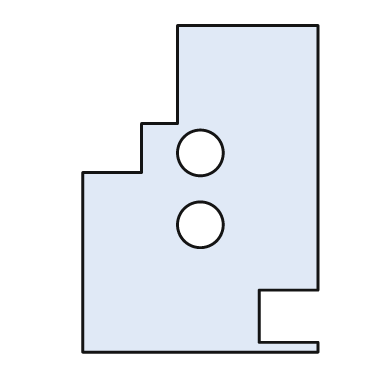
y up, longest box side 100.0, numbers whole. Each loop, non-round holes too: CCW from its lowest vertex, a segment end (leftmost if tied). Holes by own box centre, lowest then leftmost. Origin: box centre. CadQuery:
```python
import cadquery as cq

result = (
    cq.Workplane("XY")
    .moveTo(-36.0, -50.0)
    .lineTo(36.0, -50.0)
    .lineTo(36.0, -47.0)
    .lineTo(18.0, -47.0)
    .lineTo(18.0, -31.0)
    .lineTo(36.0, -31.0)
    .lineTo(36.0, 50.0)
    .lineTo(-7.0, 50.0)
    .lineTo(-7.0, 20.0)
    .lineTo(-18.0, 20.0)
    .lineTo(-18.0, 5.0)
    .lineTo(-36.0, 5.0)
    .close()
    .moveTo(0.0, -11.0)
    .circle(7.0)
    .moveTo(0.0, 11.0)
    .circle(7.0)
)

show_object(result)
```